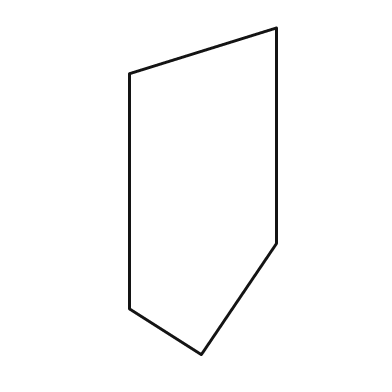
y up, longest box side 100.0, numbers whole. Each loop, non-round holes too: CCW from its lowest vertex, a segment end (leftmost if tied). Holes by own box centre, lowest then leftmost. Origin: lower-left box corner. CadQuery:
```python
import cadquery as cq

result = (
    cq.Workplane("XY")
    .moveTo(22.0, 0.0)
    .lineTo(45.0, 34.0)
    .lineTo(45.0, 100.0)
    .lineTo(0.0, 86.0)
    .lineTo(0.0, 14.0)
    .close()
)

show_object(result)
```